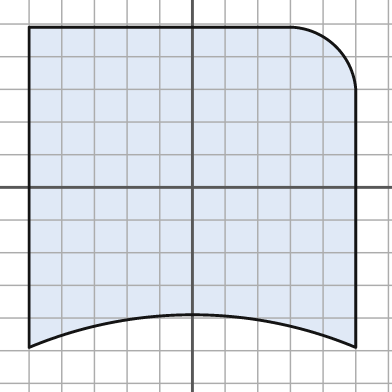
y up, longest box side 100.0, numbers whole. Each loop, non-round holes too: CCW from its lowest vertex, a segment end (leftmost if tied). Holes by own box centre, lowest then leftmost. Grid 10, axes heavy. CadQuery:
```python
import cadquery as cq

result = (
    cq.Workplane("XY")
    .moveTo(-50.0, -49.0)
    .threePointArc((0.0, -39.0), (50.0, -49.0))
    .lineTo(50.0, 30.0)
    .threePointArc((44.0, 43.0), (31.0, 49.0))
    .lineTo(-50.0, 49.0)
    .close()
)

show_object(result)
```